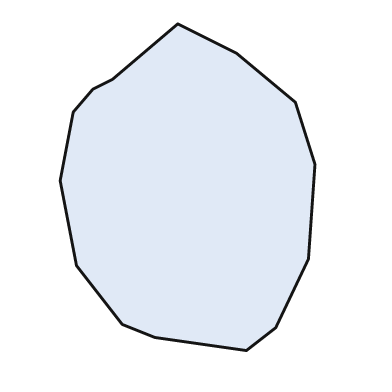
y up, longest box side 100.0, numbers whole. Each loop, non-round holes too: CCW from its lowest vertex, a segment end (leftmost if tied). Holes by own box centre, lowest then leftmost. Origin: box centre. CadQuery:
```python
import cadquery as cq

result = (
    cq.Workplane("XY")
    .moveTo(18.0, -50.0)
    .lineTo(27.0, -43.0)
    .lineTo(37.0, -22.0)
    .lineTo(39.0, 7.0)
    .lineTo(33.0, 26.0)
    .lineTo(15.0, 41.0)
    .lineTo(-3.0, 50.0)
    .lineTo(-23.0, 33.0)
    .lineTo(-29.0, 30.0)
    .lineTo(-35.0, 23.0)
    .lineTo(-39.0, 2.0)
    .lineTo(-34.0, -24.0)
    .lineTo(-20.0, -42.0)
    .lineTo(-10.0, -46.0)
    .close()
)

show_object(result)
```